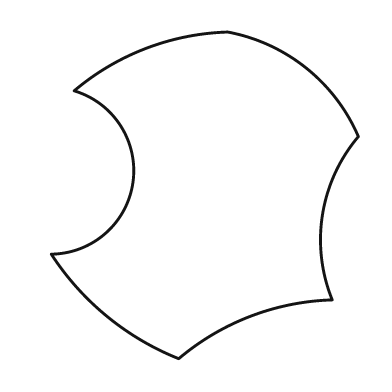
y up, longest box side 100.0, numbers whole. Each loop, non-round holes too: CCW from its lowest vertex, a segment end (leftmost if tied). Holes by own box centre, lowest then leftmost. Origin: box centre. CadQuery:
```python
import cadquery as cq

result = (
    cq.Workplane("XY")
    .moveTo(-8.0, -50.0)
    .threePointArc((14.0, -37.0), (39.0, -32.0))
    .threePointArc((36.0, -6.0), (47.0, 18.0))
    .threePointArc((31.0, 39.0), (7.0, 50.0))
    .threePointArc((-18.0, 45.0), (-40.0, 32.0))
    .threePointArc((-22.0, 4.0), (-47.0, -18.0))
    .threePointArc((-30.0, -37.0), (-8.0, -50.0))
    .close()
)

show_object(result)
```